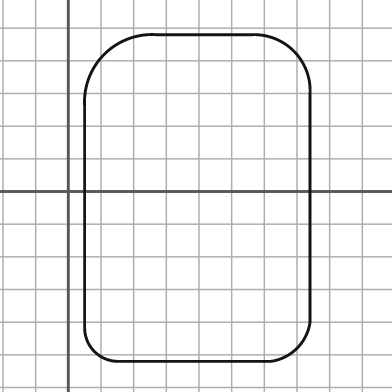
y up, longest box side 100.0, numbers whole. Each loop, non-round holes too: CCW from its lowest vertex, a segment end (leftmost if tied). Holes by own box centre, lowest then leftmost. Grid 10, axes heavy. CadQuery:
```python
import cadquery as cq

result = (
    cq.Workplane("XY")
    .moveTo(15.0, -52.0)
    .lineTo(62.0, -52.0)
    .threePointArc((70.0, -48.0), (74.0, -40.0))
    .lineTo(74.0, 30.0)
    .threePointArc((69.0, 43.0), (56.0, 48.0))
    .lineTo(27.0, 48.0)
    .threePointArc((11.0, 42.0), (5.0, 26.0))
    .lineTo(5.0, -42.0)
    .threePointArc((8.0, -49.0), (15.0, -52.0))
    .close()
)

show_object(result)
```